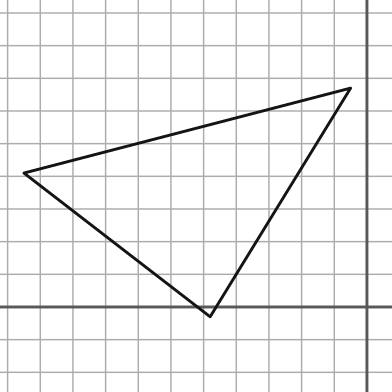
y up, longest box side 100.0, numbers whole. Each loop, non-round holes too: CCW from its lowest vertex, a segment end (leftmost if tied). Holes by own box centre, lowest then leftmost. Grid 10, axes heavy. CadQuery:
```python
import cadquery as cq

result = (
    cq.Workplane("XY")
    .moveTo(-48.0, -3.0)
    .lineTo(-5.0, 67.0)
    .lineTo(-105.0, 41.0)
    .close()
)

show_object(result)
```